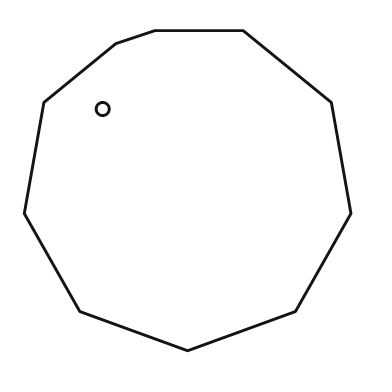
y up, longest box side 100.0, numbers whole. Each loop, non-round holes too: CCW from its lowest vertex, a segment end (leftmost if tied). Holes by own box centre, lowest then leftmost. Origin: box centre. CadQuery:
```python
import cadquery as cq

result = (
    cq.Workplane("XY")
    .moveTo(0.0, -49.0)
    .lineTo(33.0, -37.0)
    .lineTo(50.0, -7.0)
    .lineTo(44.0, 27.0)
    .lineTo(17.0, 49.0)
    .lineTo(-10.0, 49.0)
    .lineTo(-22.0, 45.0)
    .lineTo(-44.0, 27.0)
    .lineTo(-50.0, -7.0)
    .lineTo(-33.0, -37.0)
    .close()
    .moveTo(-26.0, 25.0)
    .circle(2.0)
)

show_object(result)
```